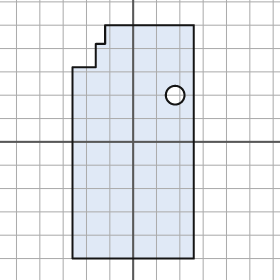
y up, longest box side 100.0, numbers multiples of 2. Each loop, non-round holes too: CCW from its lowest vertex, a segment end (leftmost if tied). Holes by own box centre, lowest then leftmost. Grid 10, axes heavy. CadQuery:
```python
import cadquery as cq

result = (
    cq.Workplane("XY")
    .moveTo(-26.0, -50.0)
    .lineTo(26.0, -50.0)
    .lineTo(26.0, 50.0)
    .lineTo(-12.0, 50.0)
    .lineTo(-12.0, 42.0)
    .lineTo(-16.0, 42.0)
    .lineTo(-16.0, 32.0)
    .lineTo(-26.0, 32.0)
    .close()
    .moveTo(18.0, 20.0)
    .circle(4.0)
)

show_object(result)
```